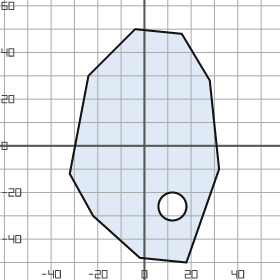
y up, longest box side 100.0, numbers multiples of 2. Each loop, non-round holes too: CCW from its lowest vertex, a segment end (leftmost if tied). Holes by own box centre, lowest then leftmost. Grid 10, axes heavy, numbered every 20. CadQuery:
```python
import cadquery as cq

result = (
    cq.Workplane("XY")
    .moveTo(18.0, -50.0)
    .lineTo(32.0, -10.0)
    .lineTo(28.0, 28.0)
    .lineTo(16.0, 48.0)
    .lineTo(-4.0, 50.0)
    .lineTo(-24.0, 30.0)
    .lineTo(-32.0, -12.0)
    .lineTo(-22.0, -30.0)
    .lineTo(-2.0, -48.0)
    .close()
    .moveTo(12.0, -26.0)
    .circle(6.0)
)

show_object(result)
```